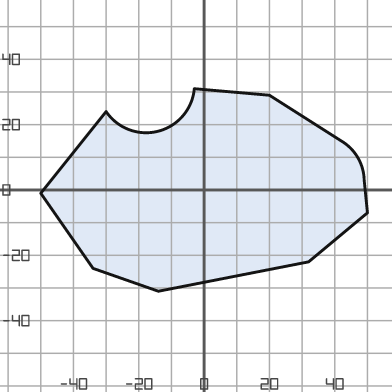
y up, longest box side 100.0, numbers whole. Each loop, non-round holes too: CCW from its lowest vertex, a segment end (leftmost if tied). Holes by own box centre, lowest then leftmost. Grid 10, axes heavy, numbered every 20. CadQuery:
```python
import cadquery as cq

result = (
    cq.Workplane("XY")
    .moveTo(-14.0, -31.0)
    .lineTo(32.0, -22.0)
    .lineTo(50.0, -7.0)
    .lineTo(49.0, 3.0)
    .threePointArc((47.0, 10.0), (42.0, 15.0))
    .lineTo(20.0, 29.0)
    .lineTo(-3.0, 31.0)
    .threePointArc((-14.0, 18.0), (-30.0, 24.0))
    .lineTo(-50.0, -1.0)
    .lineTo(-34.0, -24.0)
    .close()
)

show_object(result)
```